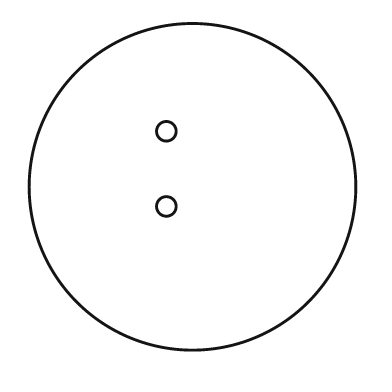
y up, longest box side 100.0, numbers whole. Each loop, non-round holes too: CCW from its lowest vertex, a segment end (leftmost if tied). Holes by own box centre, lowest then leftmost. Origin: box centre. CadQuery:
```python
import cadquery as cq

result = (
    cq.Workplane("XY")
    .moveTo(0.0, 0.0)
    .circle(50.0)
    .moveTo(-8.0, -6.0)
    .circle(3.0)
    .moveTo(-8.0, 17.0)
    .circle(3.0)
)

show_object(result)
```